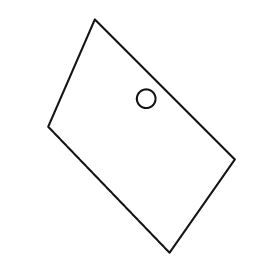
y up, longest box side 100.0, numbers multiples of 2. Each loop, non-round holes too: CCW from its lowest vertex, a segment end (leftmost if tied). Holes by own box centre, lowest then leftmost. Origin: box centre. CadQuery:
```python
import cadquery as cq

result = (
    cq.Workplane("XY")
    .moveTo(12.0, -50.0)
    .lineTo(40.0, -10.0)
    .lineTo(-20.0, 50.0)
    .lineTo(-40.0, 4.0)
    .close()
    .moveTo(2.0, 16.0)
    .circle(4.0)
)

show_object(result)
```